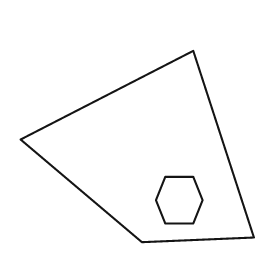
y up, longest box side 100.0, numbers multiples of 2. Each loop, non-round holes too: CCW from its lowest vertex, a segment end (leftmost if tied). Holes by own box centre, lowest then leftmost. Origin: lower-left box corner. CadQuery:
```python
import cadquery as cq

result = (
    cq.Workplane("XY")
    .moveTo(52.0, 0.0)
    .lineTo(100.0, 2.0)
    .lineTo(74.0, 82.0)
    .lineTo(0.0, 44.0)
    .close()
    .moveTo(62.0, 8.0)
    .lineTo(74.0, 8.0)
    .lineTo(78.0, 18.0)
    .lineTo(74.0, 28.0)
    .lineTo(62.0, 28.0)
    .lineTo(58.0, 18.0)
    .close()
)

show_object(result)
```